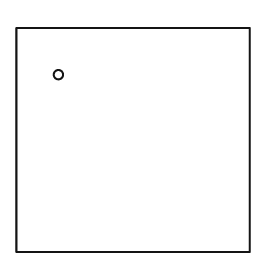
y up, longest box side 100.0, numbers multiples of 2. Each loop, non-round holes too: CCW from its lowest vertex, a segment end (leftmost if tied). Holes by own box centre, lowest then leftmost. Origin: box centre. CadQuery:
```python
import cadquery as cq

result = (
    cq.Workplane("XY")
    .moveTo(-50.0, -48.0)
    .lineTo(50.0, -48.0)
    .lineTo(50.0, 48.0)
    .lineTo(-50.0, 48.0)
    .close()
    .moveTo(-32.0, 28.0)
    .circle(2.0)
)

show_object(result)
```